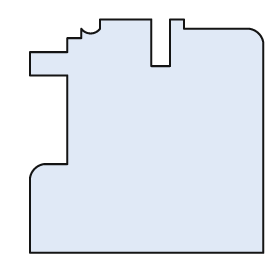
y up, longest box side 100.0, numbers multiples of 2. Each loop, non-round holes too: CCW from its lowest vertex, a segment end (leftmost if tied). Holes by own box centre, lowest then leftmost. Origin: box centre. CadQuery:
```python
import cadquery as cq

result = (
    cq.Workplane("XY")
    .moveTo(-50.0, -50.0)
    .lineTo(50.0, -50.0)
    .lineTo(50.0, 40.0)
    .threePointArc((48.0, 44.0), (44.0, 46.0))
    .lineTo(16.0, 46.0)
    .lineTo(16.0, 50.0)
    .lineTo(10.0, 50.0)
    .lineTo(10.0, 30.0)
    .lineTo(2.0, 30.0)
    .lineTo(2.0, 50.0)
    .lineTo(-20.0, 50.0)
    .lineTo(-20.0, 46.0)
    .threePointArc((-24.0, 44.0), (-28.0, 46.0))
    .lineTo(-28.0, 42.0)
    .lineTo(-34.0, 42.0)
    .lineTo(-34.0, 36.0)
    .lineTo(-50.0, 36.0)
    .lineTo(-50.0, 26.0)
    .lineTo(-34.0, 26.0)
    .lineTo(-34.0, -12.0)
    .lineTo(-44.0, -12.0)
    .threePointArc((-48.0, -14.0), (-50.0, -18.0))
    .close()
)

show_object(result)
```